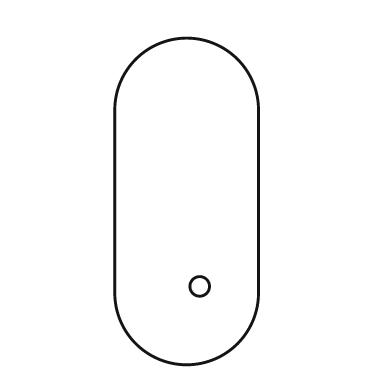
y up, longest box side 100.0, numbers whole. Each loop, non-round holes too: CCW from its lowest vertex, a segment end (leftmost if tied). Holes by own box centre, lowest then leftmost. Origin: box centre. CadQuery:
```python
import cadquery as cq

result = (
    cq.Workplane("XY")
    .moveTo(-22.0, -28.0)
    .threePointArc((0.0, -50.0), (22.0, -28.0))
    .lineTo(22.0, 28.0)
    .threePointArc((0.0, 50.0), (-22.0, 28.0))
    .close()
    .moveTo(4.0, -26.0)
    .circle(3.0)
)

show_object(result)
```